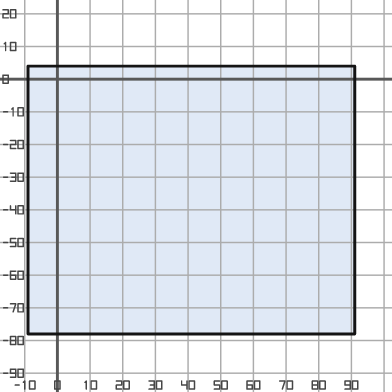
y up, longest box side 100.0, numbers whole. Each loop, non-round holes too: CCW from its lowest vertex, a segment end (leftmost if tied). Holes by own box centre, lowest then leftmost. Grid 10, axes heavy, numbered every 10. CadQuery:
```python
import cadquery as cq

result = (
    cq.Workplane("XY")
    .moveTo(-9.0, -78.0)
    .lineTo(91.0, -78.0)
    .lineTo(91.0, 4.0)
    .lineTo(-9.0, 4.0)
    .close()
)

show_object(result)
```